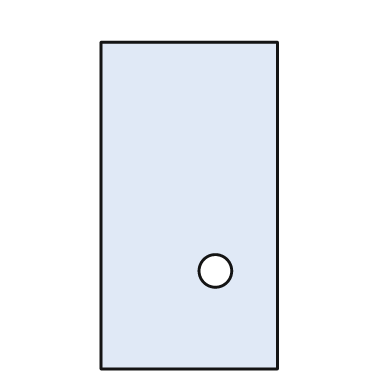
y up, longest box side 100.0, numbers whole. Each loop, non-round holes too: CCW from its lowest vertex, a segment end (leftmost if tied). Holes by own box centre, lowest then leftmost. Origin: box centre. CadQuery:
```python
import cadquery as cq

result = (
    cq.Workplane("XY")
    .moveTo(-27.0, -50.0)
    .lineTo(27.0, -50.0)
    .lineTo(27.0, 50.0)
    .lineTo(-27.0, 50.0)
    .close()
    .moveTo(8.0, -20.0)
    .circle(5.0)
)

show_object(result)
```